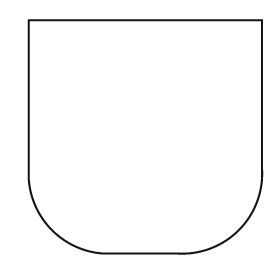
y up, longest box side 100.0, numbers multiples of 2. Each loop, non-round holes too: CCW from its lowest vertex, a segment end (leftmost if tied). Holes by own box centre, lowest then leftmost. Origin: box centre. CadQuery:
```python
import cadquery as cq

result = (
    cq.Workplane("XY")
    .moveTo(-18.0, -50.0)
    .lineTo(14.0, -50.0)
    .threePointArc((40.0, -40.0), (50.0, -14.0))
    .lineTo(50.0, 50.0)
    .lineTo(-50.0, 50.0)
    .lineTo(-50.0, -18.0)
    .threePointArc((-40.0, -40.0), (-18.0, -50.0))
    .close()
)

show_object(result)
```